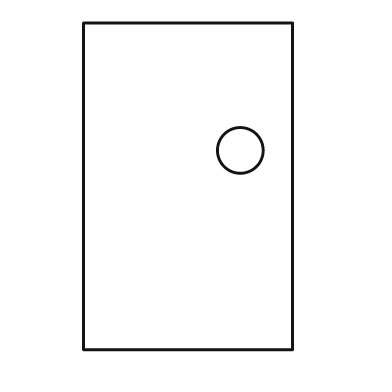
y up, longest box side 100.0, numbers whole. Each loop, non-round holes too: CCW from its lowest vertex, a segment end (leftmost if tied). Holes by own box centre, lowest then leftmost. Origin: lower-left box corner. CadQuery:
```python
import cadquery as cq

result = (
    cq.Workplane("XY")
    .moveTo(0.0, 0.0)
    .lineTo(64.0, 0.0)
    .lineTo(64.0, 100.0)
    .lineTo(0.0, 100.0)
    .close()
    .moveTo(48.0, 61.0)
    .circle(7.0)
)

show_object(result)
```